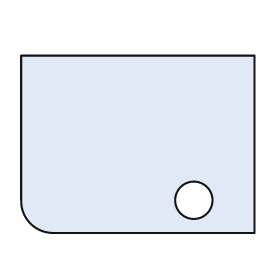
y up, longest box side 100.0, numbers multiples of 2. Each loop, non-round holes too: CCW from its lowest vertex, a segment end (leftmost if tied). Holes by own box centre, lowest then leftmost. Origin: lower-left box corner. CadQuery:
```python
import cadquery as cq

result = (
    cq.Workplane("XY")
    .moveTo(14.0, 0.0)
    .lineTo(100.0, 0.0)
    .lineTo(100.0, 76.0)
    .lineTo(0.0, 76.0)
    .lineTo(0.0, 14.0)
    .threePointArc((4.0, 4.0), (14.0, 0.0))
    .close()
    .moveTo(74.0, 14.0)
    .circle(8.0)
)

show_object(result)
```